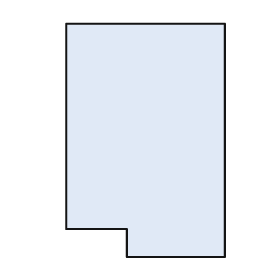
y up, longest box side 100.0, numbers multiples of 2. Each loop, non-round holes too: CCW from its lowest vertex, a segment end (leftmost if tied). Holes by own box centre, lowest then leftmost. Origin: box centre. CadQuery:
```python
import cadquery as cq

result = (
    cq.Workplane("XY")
    .moveTo(-8.0, -50.0)
    .lineTo(34.0, -50.0)
    .lineTo(34.0, 50.0)
    .lineTo(-34.0, 50.0)
    .lineTo(-34.0, -38.0)
    .lineTo(-8.0, -38.0)
    .close()
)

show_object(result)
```